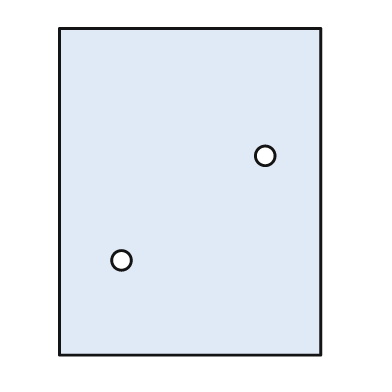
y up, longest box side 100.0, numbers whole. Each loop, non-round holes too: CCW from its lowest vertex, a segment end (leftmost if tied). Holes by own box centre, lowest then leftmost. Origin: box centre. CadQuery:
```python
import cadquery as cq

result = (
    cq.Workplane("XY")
    .moveTo(-40.0, -50.0)
    .lineTo(40.0, -50.0)
    .lineTo(40.0, 50.0)
    .lineTo(-40.0, 50.0)
    .close()
    .moveTo(-21.0, -21.0)
    .circle(3.0)
    .moveTo(23.0, 11.0)
    .circle(3.0)
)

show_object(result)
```